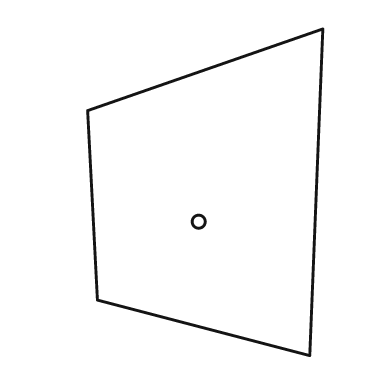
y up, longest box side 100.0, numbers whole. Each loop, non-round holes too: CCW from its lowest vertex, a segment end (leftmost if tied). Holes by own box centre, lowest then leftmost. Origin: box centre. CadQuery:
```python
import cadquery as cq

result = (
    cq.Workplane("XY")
    .moveTo(32.0, -50.0)
    .lineTo(36.0, 50.0)
    .lineTo(-36.0, 25.0)
    .lineTo(-33.0, -33.0)
    .close()
    .moveTo(-2.0, -9.0)
    .circle(2.0)
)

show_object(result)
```